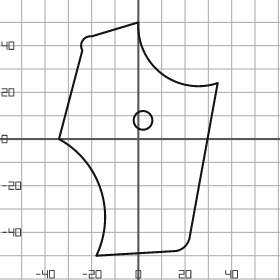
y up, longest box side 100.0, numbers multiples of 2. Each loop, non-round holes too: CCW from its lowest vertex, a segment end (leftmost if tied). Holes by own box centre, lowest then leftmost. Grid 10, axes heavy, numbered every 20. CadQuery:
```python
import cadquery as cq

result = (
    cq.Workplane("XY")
    .moveTo(-18.0, -50.0)
    .lineTo(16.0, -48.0)
    .threePointArc((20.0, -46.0), (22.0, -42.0))
    .lineTo(34.0, 24.0)
    .threePointArc((10.0, 28.0), (0.0, 50.0))
    .lineTo(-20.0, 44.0)
    .threePointArc((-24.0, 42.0), (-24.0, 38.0))
    .lineTo(-34.0, 0.0)
    .threePointArc((-16.0, -22.0), (-18.0, -50.0))
    .close()
    .moveTo(2.0, 8.0)
    .circle(4.0)
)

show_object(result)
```